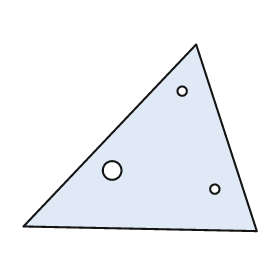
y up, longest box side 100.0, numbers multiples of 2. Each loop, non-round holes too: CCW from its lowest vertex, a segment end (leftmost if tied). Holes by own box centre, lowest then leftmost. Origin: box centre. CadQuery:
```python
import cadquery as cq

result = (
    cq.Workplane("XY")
    .moveTo(50.0, -40.0)
    .lineTo(24.0, 40.0)
    .lineTo(-50.0, -38.0)
    .close()
    .moveTo(32.0, -22.0)
    .circle(2.0)
    .moveTo(-12.0, -14.0)
    .circle(4.0)
    .moveTo(18.0, 20.0)
    .circle(2.0)
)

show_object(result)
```